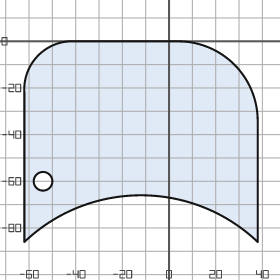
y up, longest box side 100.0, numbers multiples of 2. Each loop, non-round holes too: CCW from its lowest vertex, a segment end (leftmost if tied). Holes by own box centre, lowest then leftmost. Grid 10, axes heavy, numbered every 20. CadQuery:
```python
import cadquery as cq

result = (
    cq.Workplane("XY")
    .moveTo(-62.0, -86.0)
    .threePointArc((-12.0, -66.0), (38.0, -86.0))
    .lineTo(38.0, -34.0)
    .threePointArc((28.0, -10.0), (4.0, 0.0))
    .lineTo(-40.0, 0.0)
    .threePointArc((-56.0, -6.0), (-62.0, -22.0))
    .close()
    .moveTo(-54.0, -60.0)
    .circle(4.0)
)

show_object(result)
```